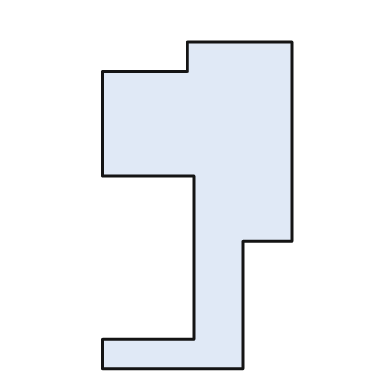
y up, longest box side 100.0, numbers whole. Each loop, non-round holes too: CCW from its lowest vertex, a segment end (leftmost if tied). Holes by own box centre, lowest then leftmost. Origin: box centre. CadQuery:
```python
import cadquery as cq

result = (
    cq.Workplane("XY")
    .moveTo(-29.0, -50.0)
    .lineTo(14.0, -50.0)
    .lineTo(14.0, -11.0)
    .lineTo(29.0, -11.0)
    .lineTo(29.0, 50.0)
    .lineTo(-3.0, 50.0)
    .lineTo(-3.0, 41.0)
    .lineTo(-29.0, 41.0)
    .lineTo(-29.0, 9.0)
    .lineTo(-1.0, 9.0)
    .lineTo(-1.0, -41.0)
    .lineTo(-29.0, -41.0)
    .close()
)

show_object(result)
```